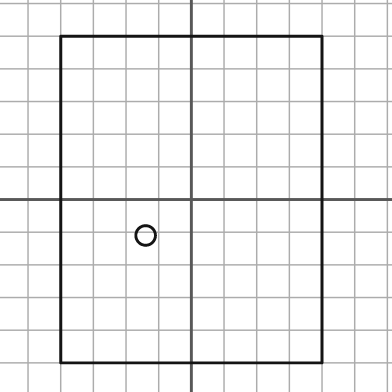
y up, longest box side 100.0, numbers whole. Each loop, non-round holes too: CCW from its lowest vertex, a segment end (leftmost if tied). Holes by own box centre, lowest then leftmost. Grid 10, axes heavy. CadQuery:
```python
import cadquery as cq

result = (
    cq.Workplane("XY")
    .moveTo(-40.0, -50.0)
    .lineTo(40.0, -50.0)
    .lineTo(40.0, 50.0)
    .lineTo(-40.0, 50.0)
    .close()
    .moveTo(-14.0, -11.0)
    .circle(3.0)
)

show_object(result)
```